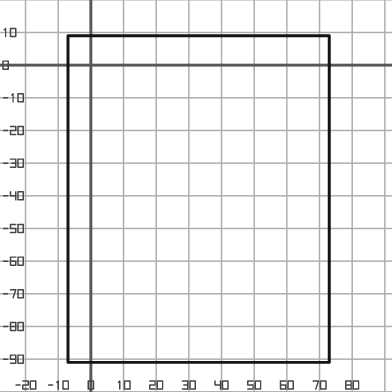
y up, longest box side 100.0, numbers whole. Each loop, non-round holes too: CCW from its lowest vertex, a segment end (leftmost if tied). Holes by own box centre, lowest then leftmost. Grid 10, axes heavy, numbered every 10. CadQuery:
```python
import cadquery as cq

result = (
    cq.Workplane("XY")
    .moveTo(-7.0, -91.0)
    .lineTo(73.0, -91.0)
    .lineTo(73.0, 9.0)
    .lineTo(-7.0, 9.0)
    .close()
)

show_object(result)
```